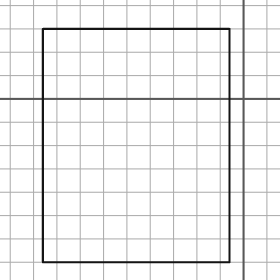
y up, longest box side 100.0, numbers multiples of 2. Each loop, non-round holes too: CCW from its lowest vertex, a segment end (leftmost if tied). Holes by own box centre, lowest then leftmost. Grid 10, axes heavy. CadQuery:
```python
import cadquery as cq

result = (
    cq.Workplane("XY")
    .moveTo(-86.0, -70.0)
    .lineTo(-6.0, -70.0)
    .lineTo(-6.0, 30.0)
    .lineTo(-86.0, 30.0)
    .close()
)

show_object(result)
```